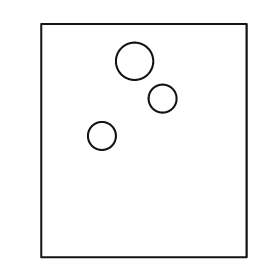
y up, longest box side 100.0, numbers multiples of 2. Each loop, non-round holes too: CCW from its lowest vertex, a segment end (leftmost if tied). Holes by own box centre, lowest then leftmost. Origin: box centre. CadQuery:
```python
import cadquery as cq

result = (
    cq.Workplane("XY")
    .moveTo(-44.0, -50.0)
    .lineTo(44.0, -50.0)
    .lineTo(44.0, 50.0)
    .lineTo(-44.0, 50.0)
    .close()
    .moveTo(-18.0, 2.0)
    .circle(6.0)
    .moveTo(8.0, 18.0)
    .circle(6.0)
    .moveTo(-4.0, 34.0)
    .circle(8.0)
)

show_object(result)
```